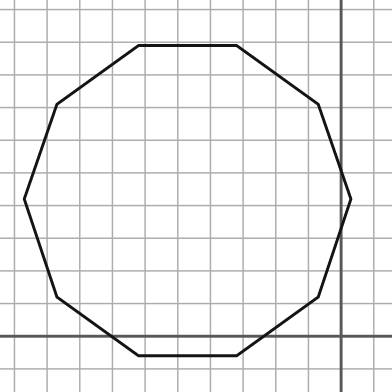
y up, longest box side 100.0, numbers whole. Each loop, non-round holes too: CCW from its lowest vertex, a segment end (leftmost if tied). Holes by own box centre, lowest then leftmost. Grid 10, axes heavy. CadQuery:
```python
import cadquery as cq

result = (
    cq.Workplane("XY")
    .moveTo(-62.0, -6.0)
    .lineTo(-32.0, -6.0)
    .lineTo(-7.0, 12.0)
    .lineTo(3.0, 42.0)
    .lineTo(-7.0, 71.0)
    .lineTo(-32.0, 89.0)
    .lineTo(-62.0, 89.0)
    .lineTo(-87.0, 71.0)
    .lineTo(-97.0, 42.0)
    .lineTo(-87.0, 12.0)
    .close()
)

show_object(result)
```